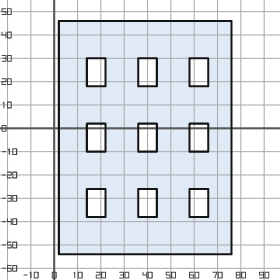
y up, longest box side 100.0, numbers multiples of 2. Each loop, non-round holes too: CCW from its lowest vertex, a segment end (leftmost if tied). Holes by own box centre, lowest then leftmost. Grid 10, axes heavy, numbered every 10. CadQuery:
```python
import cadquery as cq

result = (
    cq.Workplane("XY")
    .moveTo(2.0, -54.0)
    .lineTo(76.0, -54.0)
    .lineTo(76.0, 46.0)
    .lineTo(2.0, 46.0)
    .close()
    .moveTo(14.0, -38.0)
    .lineTo(22.0, -38.0)
    .lineTo(22.0, -26.0)
    .lineTo(14.0, -26.0)
    .close()
    .moveTo(36.0, -38.0)
    .lineTo(44.0, -38.0)
    .lineTo(44.0, -26.0)
    .lineTo(36.0, -26.0)
    .close()
    .moveTo(58.0, -38.0)
    .lineTo(66.0, -38.0)
    .lineTo(66.0, -26.0)
    .lineTo(58.0, -26.0)
    .close()
    .moveTo(14.0, -10.0)
    .lineTo(22.0, -10.0)
    .lineTo(22.0, 2.0)
    .lineTo(14.0, 2.0)
    .close()
    .moveTo(36.0, -10.0)
    .lineTo(44.0, -10.0)
    .lineTo(44.0, 2.0)
    .lineTo(36.0, 2.0)
    .close()
    .moveTo(58.0, -10.0)
    .lineTo(66.0, -10.0)
    .lineTo(66.0, 2.0)
    .lineTo(58.0, 2.0)
    .close()
    .moveTo(14.0, 18.0)
    .lineTo(22.0, 18.0)
    .lineTo(22.0, 30.0)
    .lineTo(14.0, 30.0)
    .close()
    .moveTo(36.0, 18.0)
    .lineTo(44.0, 18.0)
    .lineTo(44.0, 30.0)
    .lineTo(36.0, 30.0)
    .close()
    .moveTo(58.0, 18.0)
    .lineTo(66.0, 18.0)
    .lineTo(66.0, 30.0)
    .lineTo(58.0, 30.0)
    .close()
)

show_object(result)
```